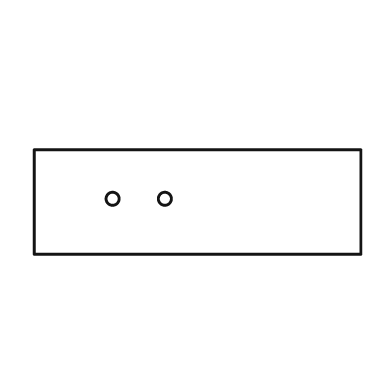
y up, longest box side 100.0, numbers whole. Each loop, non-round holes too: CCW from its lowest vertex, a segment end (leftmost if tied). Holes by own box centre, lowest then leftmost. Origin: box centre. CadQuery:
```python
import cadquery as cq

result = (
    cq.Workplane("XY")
    .moveTo(-50.0, -16.0)
    .lineTo(50.0, -16.0)
    .lineTo(50.0, 16.0)
    .lineTo(-50.0, 16.0)
    .close()
    .moveTo(-26.0, 1.0)
    .circle(2.0)
    .moveTo(-10.0, 1.0)
    .circle(2.0)
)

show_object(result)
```